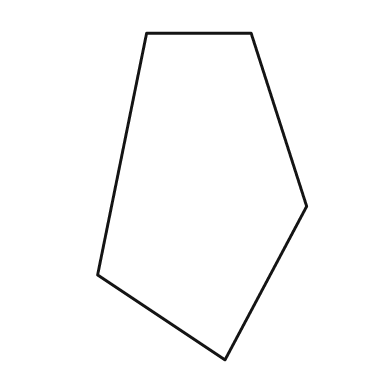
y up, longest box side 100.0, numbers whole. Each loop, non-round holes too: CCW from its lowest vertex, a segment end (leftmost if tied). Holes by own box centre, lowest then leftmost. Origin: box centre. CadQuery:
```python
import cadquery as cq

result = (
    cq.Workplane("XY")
    .moveTo(7.0, -50.0)
    .lineTo(32.0, -3.0)
    .lineTo(15.0, 50.0)
    .lineTo(-17.0, 50.0)
    .lineTo(-32.0, -24.0)
    .close()
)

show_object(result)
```